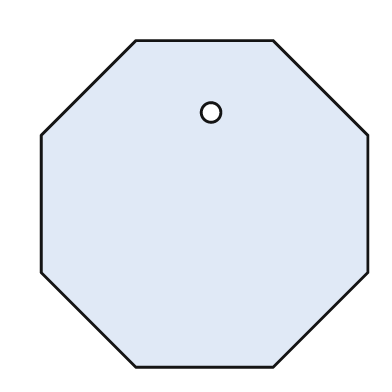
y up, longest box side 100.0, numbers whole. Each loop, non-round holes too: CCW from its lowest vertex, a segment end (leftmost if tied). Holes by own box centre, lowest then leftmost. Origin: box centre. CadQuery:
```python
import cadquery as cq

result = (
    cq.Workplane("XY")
    .moveTo(-21.0, -50.0)
    .lineTo(21.0, -50.0)
    .lineTo(50.0, -21.0)
    .lineTo(50.0, 21.0)
    .lineTo(21.0, 50.0)
    .lineTo(-21.0, 50.0)
    .lineTo(-50.0, 21.0)
    .lineTo(-50.0, -21.0)
    .close()
    .moveTo(2.0, 28.0)
    .circle(3.0)
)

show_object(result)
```